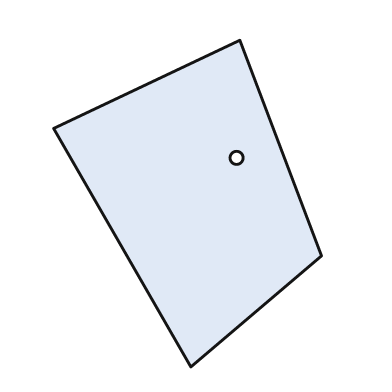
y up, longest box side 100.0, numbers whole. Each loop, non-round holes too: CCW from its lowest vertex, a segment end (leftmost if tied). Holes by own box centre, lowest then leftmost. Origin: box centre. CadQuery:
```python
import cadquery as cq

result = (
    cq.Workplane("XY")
    .moveTo(1.0, -50.0)
    .lineTo(41.0, -16.0)
    .lineTo(16.0, 50.0)
    .lineTo(-41.0, 23.0)
    .close()
    .moveTo(15.0, 14.0)
    .circle(2.0)
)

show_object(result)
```